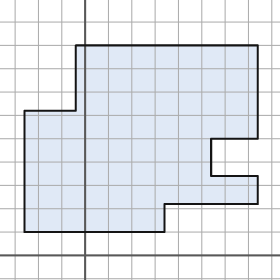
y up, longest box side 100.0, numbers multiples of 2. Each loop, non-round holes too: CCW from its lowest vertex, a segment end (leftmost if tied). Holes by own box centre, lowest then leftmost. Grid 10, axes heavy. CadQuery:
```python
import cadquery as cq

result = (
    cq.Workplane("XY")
    .moveTo(-26.0, 10.0)
    .lineTo(34.0, 10.0)
    .lineTo(34.0, 22.0)
    .lineTo(74.0, 22.0)
    .lineTo(74.0, 34.0)
    .lineTo(54.0, 34.0)
    .lineTo(54.0, 50.0)
    .lineTo(74.0, 50.0)
    .lineTo(74.0, 90.0)
    .lineTo(-4.0, 90.0)
    .lineTo(-4.0, 62.0)
    .lineTo(-26.0, 62.0)
    .close()
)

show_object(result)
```